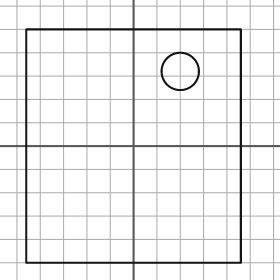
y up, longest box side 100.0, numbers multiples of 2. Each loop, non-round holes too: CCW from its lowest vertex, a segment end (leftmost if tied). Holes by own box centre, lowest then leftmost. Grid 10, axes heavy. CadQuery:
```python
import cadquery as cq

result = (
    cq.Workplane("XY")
    .moveTo(-46.0, -50.0)
    .lineTo(46.0, -50.0)
    .lineTo(46.0, 50.0)
    .lineTo(-46.0, 50.0)
    .close()
    .moveTo(20.0, 32.0)
    .circle(8.0)
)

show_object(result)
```